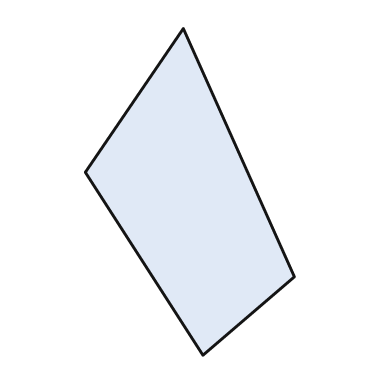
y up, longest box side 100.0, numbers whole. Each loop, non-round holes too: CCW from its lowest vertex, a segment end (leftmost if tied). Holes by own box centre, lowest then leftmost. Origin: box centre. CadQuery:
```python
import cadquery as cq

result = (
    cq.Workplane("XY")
    .moveTo(4.0, -50.0)
    .lineTo(32.0, -26.0)
    .lineTo(-2.0, 50.0)
    .lineTo(-32.0, 6.0)
    .close()
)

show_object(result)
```